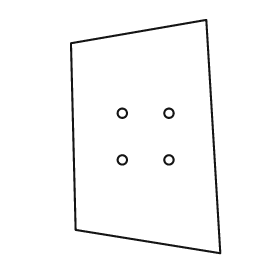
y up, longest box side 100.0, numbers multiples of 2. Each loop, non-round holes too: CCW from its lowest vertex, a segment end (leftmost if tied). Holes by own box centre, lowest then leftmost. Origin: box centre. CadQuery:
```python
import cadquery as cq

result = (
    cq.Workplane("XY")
    .moveTo(32.0, -50.0)
    .lineTo(26.0, 50.0)
    .lineTo(-32.0, 40.0)
    .lineTo(-30.0, -40.0)
    .close()
    .moveTo(-10.0, -10.0)
    .circle(2.0)
    .moveTo(10.0, -10.0)
    .circle(2.0)
    .moveTo(-10.0, 10.0)
    .circle(2.0)
    .moveTo(10.0, 10.0)
    .circle(2.0)
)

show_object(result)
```